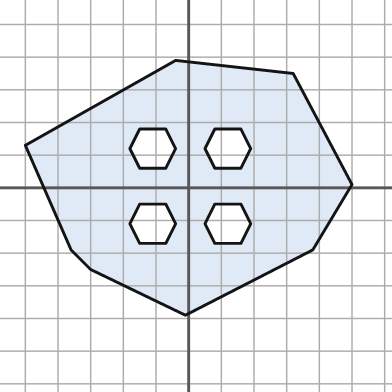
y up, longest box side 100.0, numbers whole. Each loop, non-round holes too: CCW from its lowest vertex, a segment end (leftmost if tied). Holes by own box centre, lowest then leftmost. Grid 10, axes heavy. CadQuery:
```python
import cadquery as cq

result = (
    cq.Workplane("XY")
    .moveTo(-1.0, -39.0)
    .lineTo(38.0, -19.0)
    .lineTo(50.0, 1.0)
    .lineTo(32.0, 35.0)
    .lineTo(-4.0, 39.0)
    .lineTo(-50.0, 13.0)
    .lineTo(-36.0, -19.0)
    .lineTo(-30.0, -25.0)
    .close()
    .moveTo(-15.0, -17.0)
    .lineTo(-7.0, -17.0)
    .lineTo(-4.0, -11.0)
    .lineTo(-7.0, -5.0)
    .lineTo(-15.0, -5.0)
    .lineTo(-18.0, -11.0)
    .close()
    .moveTo(8.0, -17.0)
    .lineTo(16.0, -17.0)
    .lineTo(19.0, -11.0)
    .lineTo(16.0, -5.0)
    .lineTo(8.0, -5.0)
    .lineTo(5.0, -11.0)
    .close()
    .moveTo(-15.0, 6.0)
    .lineTo(-7.0, 6.0)
    .lineTo(-4.0, 12.0)
    .lineTo(-7.0, 18.0)
    .lineTo(-15.0, 18.0)
    .lineTo(-18.0, 12.0)
    .close()
    .moveTo(8.0, 6.0)
    .lineTo(16.0, 6.0)
    .lineTo(19.0, 12.0)
    .lineTo(16.0, 18.0)
    .lineTo(8.0, 18.0)
    .lineTo(5.0, 12.0)
    .close()
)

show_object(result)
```